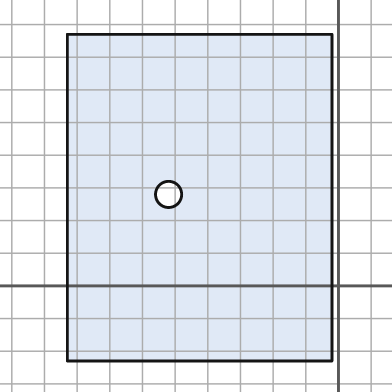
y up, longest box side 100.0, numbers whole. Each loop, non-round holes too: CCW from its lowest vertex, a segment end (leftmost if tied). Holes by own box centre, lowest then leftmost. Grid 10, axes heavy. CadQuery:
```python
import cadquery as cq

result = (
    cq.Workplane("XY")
    .moveTo(-83.0, -23.0)
    .lineTo(-2.0, -23.0)
    .lineTo(-2.0, 77.0)
    .lineTo(-83.0, 77.0)
    .close()
    .moveTo(-52.0, 28.0)
    .circle(4.0)
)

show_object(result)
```